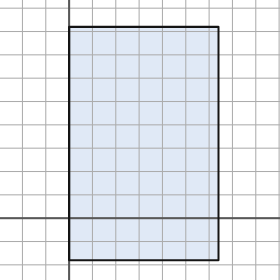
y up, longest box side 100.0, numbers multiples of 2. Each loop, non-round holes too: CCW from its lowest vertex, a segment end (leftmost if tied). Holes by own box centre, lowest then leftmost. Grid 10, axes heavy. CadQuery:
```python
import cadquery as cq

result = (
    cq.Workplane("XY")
    .moveTo(0.0, -18.0)
    .lineTo(64.0, -18.0)
    .lineTo(64.0, 82.0)
    .lineTo(0.0, 82.0)
    .close()
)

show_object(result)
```